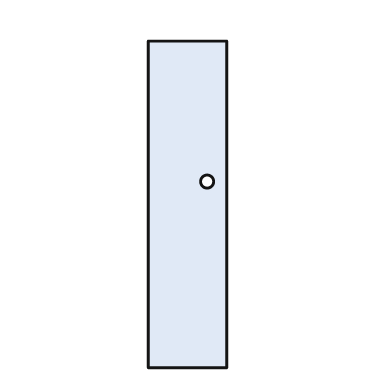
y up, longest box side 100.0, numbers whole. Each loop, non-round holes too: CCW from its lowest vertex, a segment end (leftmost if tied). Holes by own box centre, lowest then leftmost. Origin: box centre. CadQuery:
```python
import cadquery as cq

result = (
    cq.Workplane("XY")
    .moveTo(-12.0, -50.0)
    .lineTo(12.0, -50.0)
    .lineTo(12.0, 50.0)
    .lineTo(-12.0, 50.0)
    .close()
    .moveTo(6.0, 7.0)
    .circle(2.0)
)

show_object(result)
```